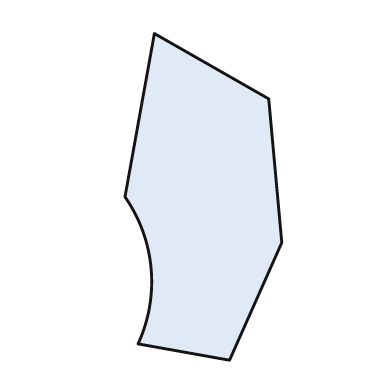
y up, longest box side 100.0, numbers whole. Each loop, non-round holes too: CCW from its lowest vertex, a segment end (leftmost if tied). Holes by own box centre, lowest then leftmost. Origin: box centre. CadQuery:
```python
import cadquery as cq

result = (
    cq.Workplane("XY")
    .moveTo(8.0, -50.0)
    .lineTo(24.0, -14.0)
    .lineTo(20.0, 30.0)
    .lineTo(-15.0, 50.0)
    .lineTo(-24.0, 0.0)
    .threePointArc((-16.0, -22.0), (-20.0, -45.0))
    .close()
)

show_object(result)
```